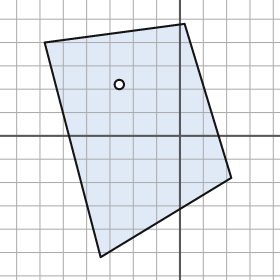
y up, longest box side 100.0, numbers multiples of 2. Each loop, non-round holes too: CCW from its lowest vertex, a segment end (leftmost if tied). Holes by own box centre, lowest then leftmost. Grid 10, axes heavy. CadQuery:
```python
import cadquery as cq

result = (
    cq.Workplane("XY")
    .moveTo(-34.0, -52.0)
    .lineTo(22.0, -18.0)
    .lineTo(2.0, 48.0)
    .lineTo(-58.0, 40.0)
    .close()
    .moveTo(-26.0, 22.0)
    .circle(2.0)
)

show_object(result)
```